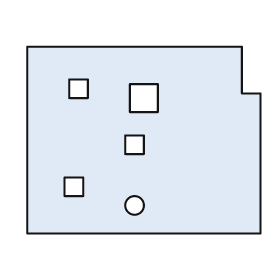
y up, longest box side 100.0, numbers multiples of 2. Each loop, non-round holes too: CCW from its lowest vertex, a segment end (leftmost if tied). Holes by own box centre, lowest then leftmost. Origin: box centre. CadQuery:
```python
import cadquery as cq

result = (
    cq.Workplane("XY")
    .moveTo(-50.0, -40.0)
    .lineTo(50.0, -40.0)
    .lineTo(50.0, 20.0)
    .lineTo(42.0, 20.0)
    .lineTo(42.0, 40.0)
    .lineTo(-50.0, 40.0)
    .close()
    .moveTo(-4.0, -28.0)
    .circle(4.0)
    .moveTo(-34.0, -24.0)
    .lineTo(-26.0, -24.0)
    .lineTo(-26.0, -16.0)
    .lineTo(-34.0, -16.0)
    .close()
    .moveTo(-8.0, -6.0)
    .lineTo(0.0, -6.0)
    .lineTo(0.0, 2.0)
    .lineTo(-8.0, 2.0)
    .close()
    .moveTo(-6.0, 12.0)
    .lineTo(6.0, 12.0)
    .lineTo(6.0, 24.0)
    .lineTo(-6.0, 24.0)
    .close()
    .moveTo(-32.0, 18.0)
    .lineTo(-24.0, 18.0)
    .lineTo(-24.0, 26.0)
    .lineTo(-32.0, 26.0)
    .close()
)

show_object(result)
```